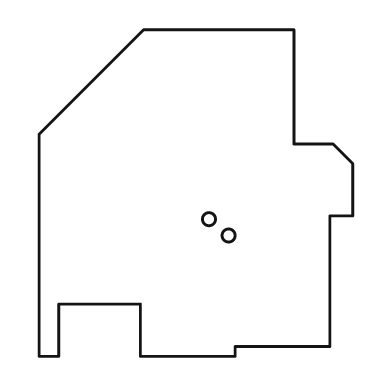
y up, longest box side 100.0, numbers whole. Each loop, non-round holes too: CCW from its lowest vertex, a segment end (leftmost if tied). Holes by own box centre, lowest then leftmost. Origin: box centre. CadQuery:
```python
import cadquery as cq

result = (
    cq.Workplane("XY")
    .moveTo(-48.0, -50.0)
    .lineTo(-42.0, -50.0)
    .lineTo(-42.0, -34.0)
    .lineTo(-17.0, -34.0)
    .lineTo(-17.0, -50.0)
    .lineTo(12.0, -50.0)
    .lineTo(12.0, -47.0)
    .lineTo(41.0, -47.0)
    .lineTo(41.0, -7.0)
    .lineTo(48.0, -7.0)
    .lineTo(48.0, 9.0)
    .lineTo(42.0, 15.0)
    .lineTo(30.0, 15.0)
    .lineTo(30.0, 50.0)
    .lineTo(-16.0, 50.0)
    .lineTo(-48.0, 18.0)
    .close()
    .moveTo(10.0, -13.0)
    .circle(2.0)
    .moveTo(4.0, -8.0)
    .circle(2.0)
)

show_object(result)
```